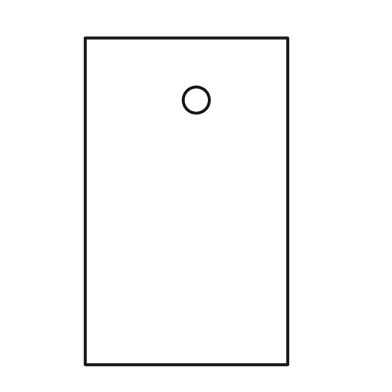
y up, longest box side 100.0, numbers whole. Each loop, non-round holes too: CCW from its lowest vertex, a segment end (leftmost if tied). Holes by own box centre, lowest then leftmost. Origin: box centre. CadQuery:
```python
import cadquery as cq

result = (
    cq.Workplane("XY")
    .moveTo(-31.0, -50.0)
    .lineTo(31.0, -50.0)
    .lineTo(31.0, 50.0)
    .lineTo(-31.0, 50.0)
    .close()
    .moveTo(3.0, 31.0)
    .circle(4.0)
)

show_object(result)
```